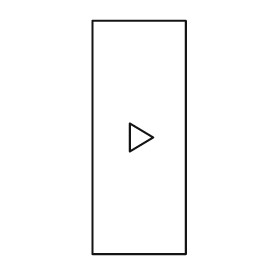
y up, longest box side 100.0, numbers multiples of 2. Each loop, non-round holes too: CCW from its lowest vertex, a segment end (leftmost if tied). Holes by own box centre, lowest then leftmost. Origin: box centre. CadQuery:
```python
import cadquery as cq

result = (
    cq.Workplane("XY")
    .moveTo(-20.0, -50.0)
    .lineTo(20.0, -50.0)
    .lineTo(20.0, 50.0)
    .lineTo(-20.0, 50.0)
    .close()
    .moveTo(-4.0, -6.0)
    .lineTo(6.0, 0.0)
    .lineTo(-4.0, 6.0)
    .close()
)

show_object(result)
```